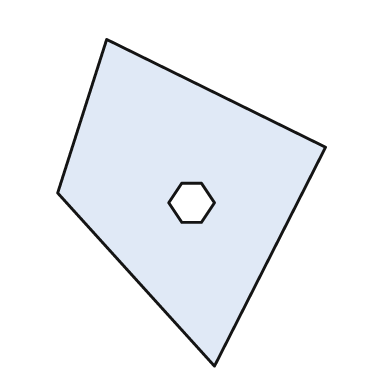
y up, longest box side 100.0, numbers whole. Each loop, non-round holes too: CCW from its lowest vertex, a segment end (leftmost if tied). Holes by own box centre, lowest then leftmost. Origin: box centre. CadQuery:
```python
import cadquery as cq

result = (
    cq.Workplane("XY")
    .moveTo(7.0, -50.0)
    .lineTo(41.0, 17.0)
    .lineTo(-26.0, 50.0)
    .lineTo(-41.0, 3.0)
    .close()
    .moveTo(-3.0, -6.0)
    .lineTo(3.0, -6.0)
    .lineTo(7.0, 0.0)
    .lineTo(3.0, 6.0)
    .lineTo(-3.0, 6.0)
    .lineTo(-7.0, 0.0)
    .close()
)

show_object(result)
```